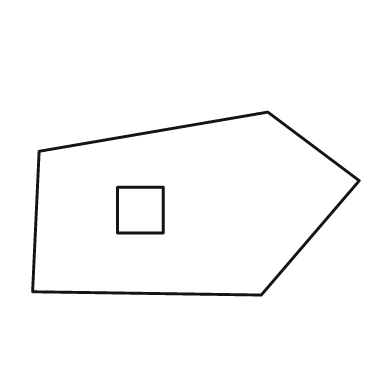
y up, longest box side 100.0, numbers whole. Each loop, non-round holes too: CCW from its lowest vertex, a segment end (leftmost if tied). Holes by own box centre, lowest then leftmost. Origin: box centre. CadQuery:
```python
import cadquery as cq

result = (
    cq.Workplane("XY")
    .moveTo(20.0, -28.0)
    .lineTo(50.0, 7.0)
    .lineTo(22.0, 28.0)
    .lineTo(-48.0, 16.0)
    .lineTo(-50.0, -27.0)
    .close()
    .moveTo(-24.0, -9.0)
    .lineTo(-10.0, -9.0)
    .lineTo(-10.0, 5.0)
    .lineTo(-24.0, 5.0)
    .close()
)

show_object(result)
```